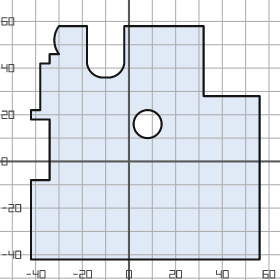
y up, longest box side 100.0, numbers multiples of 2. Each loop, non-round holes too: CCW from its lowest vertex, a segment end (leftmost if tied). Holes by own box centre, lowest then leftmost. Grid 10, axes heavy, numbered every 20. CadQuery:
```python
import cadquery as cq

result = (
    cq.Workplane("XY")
    .moveTo(-42.0, -42.0)
    .lineTo(56.0, -42.0)
    .lineTo(56.0, 28.0)
    .lineTo(32.0, 28.0)
    .lineTo(32.0, 58.0)
    .lineTo(-2.0, 58.0)
    .lineTo(-2.0, 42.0)
    .threePointArc((-4.0, 38.0), (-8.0, 36.0))
    .lineTo(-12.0, 36.0)
    .threePointArc((-16.0, 38.0), (-18.0, 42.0))
    .lineTo(-18.0, 58.0)
    .lineTo(-30.0, 58.0)
    .threePointArc((-32.0, 52.0), (-30.0, 46.0))
    .lineTo(-34.0, 46.0)
    .lineTo(-34.0, 42.0)
    .lineTo(-38.0, 42.0)
    .lineTo(-38.0, 22.0)
    .lineTo(-42.0, 22.0)
    .lineTo(-42.0, 18.0)
    .lineTo(-34.0, 18.0)
    .lineTo(-34.0, -8.0)
    .lineTo(-42.0, -8.0)
    .close()
    .moveTo(8.0, 16.0)
    .circle(6.0)
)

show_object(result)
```